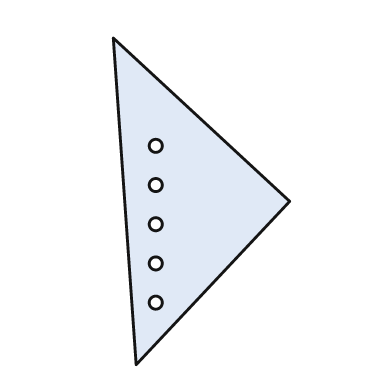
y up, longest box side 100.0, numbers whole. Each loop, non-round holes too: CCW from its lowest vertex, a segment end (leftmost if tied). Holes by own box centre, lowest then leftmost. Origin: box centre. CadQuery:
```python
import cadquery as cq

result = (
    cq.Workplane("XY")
    .moveTo(-20.0, -50.0)
    .lineTo(27.0, 0.0)
    .lineTo(-27.0, 50.0)
    .close()
    .moveTo(-14.0, -31.0)
    .circle(2.0)
    .moveTo(-14.0, -19.0)
    .circle(2.0)
    .moveTo(-14.0, -7.0)
    .circle(2.0)
    .moveTo(-14.0, 5.0)
    .circle(2.0)
    .moveTo(-14.0, 17.0)
    .circle(2.0)
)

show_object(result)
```